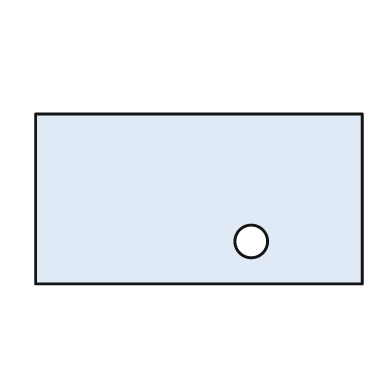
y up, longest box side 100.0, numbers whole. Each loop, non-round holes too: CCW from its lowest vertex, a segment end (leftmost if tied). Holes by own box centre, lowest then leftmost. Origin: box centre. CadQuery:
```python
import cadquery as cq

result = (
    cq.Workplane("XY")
    .moveTo(-50.0, -26.0)
    .lineTo(50.0, -26.0)
    .lineTo(50.0, 26.0)
    .lineTo(-50.0, 26.0)
    .close()
    .moveTo(16.0, -13.0)
    .circle(5.0)
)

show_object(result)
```